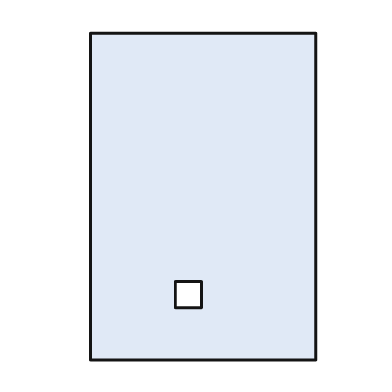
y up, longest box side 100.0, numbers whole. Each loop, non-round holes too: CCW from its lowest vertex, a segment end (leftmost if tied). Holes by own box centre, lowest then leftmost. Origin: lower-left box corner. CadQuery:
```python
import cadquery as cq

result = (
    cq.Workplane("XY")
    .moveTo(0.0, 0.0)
    .lineTo(69.0, 0.0)
    .lineTo(69.0, 100.0)
    .lineTo(0.0, 100.0)
    .close()
    .moveTo(26.0, 16.0)
    .lineTo(34.0, 16.0)
    .lineTo(34.0, 24.0)
    .lineTo(26.0, 24.0)
    .close()
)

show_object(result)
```